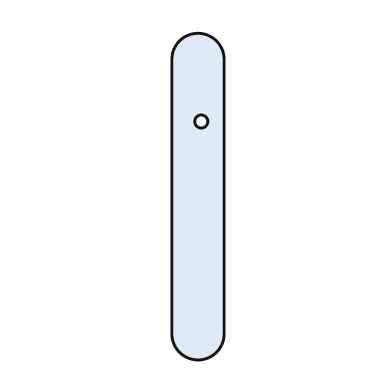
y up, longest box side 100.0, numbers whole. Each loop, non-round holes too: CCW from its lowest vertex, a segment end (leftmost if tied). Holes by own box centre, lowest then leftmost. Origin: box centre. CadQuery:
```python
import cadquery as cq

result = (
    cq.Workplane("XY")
    .moveTo(-8.0, -42.0)
    .threePointArc((0.0, -50.0), (8.0, -42.0))
    .lineTo(8.0, 42.0)
    .threePointArc((0.0, 50.0), (-8.0, 42.0))
    .close()
    .moveTo(1.0, 23.0)
    .circle(2.0)
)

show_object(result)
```